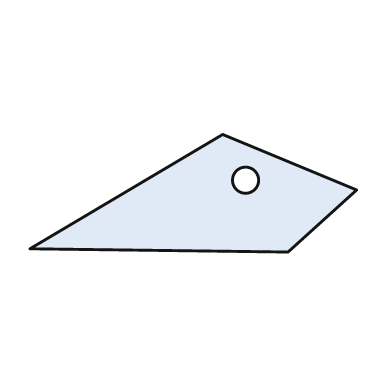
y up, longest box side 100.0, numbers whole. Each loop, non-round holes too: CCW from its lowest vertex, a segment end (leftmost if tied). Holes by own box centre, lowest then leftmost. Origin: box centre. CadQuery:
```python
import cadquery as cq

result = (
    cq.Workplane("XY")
    .moveTo(29.0, -18.0)
    .lineTo(50.0, 1.0)
    .lineTo(9.0, 18.0)
    .lineTo(-50.0, -17.0)
    .close()
    .moveTo(16.0, 4.0)
    .circle(4.0)
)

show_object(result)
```